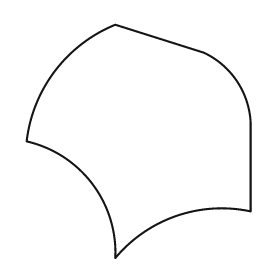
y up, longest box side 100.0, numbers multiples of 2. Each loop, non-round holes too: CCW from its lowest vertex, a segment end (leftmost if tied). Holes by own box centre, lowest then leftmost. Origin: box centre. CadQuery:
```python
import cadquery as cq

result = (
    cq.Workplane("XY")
    .moveTo(-10.0, -50.0)
    .threePointArc((16.0, -32.0), (48.0, -30.0))
    .lineTo(48.0, 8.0)
    .threePointArc((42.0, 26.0), (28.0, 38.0))
    .lineTo(-10.0, 50.0)
    .threePointArc((-36.0, 30.0), (-48.0, 0.0))
    .threePointArc((-20.0, -18.0), (-10.0, -50.0))
    .close()
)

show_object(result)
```